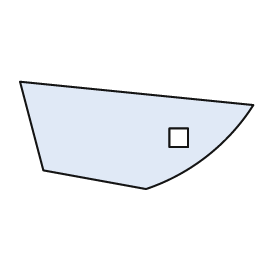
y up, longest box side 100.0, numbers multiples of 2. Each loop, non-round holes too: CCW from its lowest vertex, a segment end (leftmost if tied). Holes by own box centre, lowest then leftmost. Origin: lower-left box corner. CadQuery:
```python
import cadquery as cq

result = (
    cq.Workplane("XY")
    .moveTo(54.0, 0.0)
    .threePointArc((80.0, 14.0), (100.0, 36.0))
    .lineTo(0.0, 46.0)
    .lineTo(10.0, 8.0)
    .close()
    .moveTo(64.0, 18.0)
    .lineTo(72.0, 18.0)
    .lineTo(72.0, 26.0)
    .lineTo(64.0, 26.0)
    .close()
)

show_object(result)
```